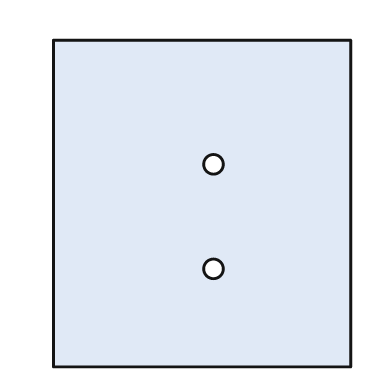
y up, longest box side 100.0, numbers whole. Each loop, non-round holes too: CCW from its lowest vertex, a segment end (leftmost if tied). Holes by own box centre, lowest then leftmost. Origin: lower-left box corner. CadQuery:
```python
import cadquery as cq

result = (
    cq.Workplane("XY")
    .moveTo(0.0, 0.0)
    .lineTo(91.0, 0.0)
    .lineTo(91.0, 100.0)
    .lineTo(0.0, 100.0)
    .close()
    .moveTo(49.0, 30.0)
    .circle(3.0)
    .moveTo(49.0, 62.0)
    .circle(3.0)
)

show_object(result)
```